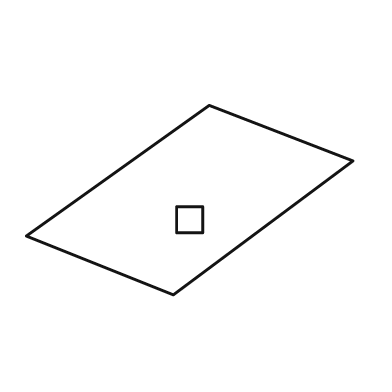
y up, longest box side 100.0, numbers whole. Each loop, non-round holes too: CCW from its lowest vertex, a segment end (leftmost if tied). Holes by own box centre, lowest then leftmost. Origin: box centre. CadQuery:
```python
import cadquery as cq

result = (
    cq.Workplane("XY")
    .moveTo(-5.0, -29.0)
    .lineTo(50.0, 12.0)
    .lineTo(6.0, 29.0)
    .lineTo(-50.0, -11.0)
    .close()
    .moveTo(-4.0, -10.0)
    .lineTo(4.0, -10.0)
    .lineTo(4.0, -2.0)
    .lineTo(-4.0, -2.0)
    .close()
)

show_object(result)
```